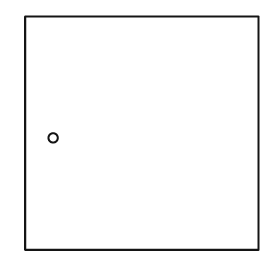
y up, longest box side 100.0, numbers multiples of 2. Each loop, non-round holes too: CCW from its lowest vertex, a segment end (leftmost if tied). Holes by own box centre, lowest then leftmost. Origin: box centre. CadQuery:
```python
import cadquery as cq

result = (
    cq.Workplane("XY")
    .moveTo(-50.0, -50.0)
    .lineTo(50.0, -50.0)
    .lineTo(50.0, 50.0)
    .lineTo(-50.0, 50.0)
    .close()
    .moveTo(-38.0, -2.0)
    .circle(2.0)
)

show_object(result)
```